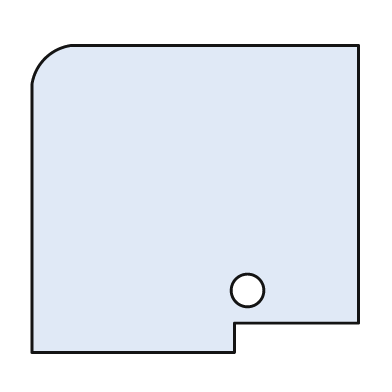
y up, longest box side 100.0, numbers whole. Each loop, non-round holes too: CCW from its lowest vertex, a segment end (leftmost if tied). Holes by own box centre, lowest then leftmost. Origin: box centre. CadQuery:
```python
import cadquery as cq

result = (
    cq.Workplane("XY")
    .moveTo(-50.0, -47.0)
    .lineTo(12.0, -47.0)
    .lineTo(12.0, -38.0)
    .lineTo(50.0, -38.0)
    .lineTo(50.0, 47.0)
    .lineTo(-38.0, 47.0)
    .threePointArc((-46.0, 43.0), (-50.0, 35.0))
    .close()
    .moveTo(16.0, -28.0)
    .circle(5.0)
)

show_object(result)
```